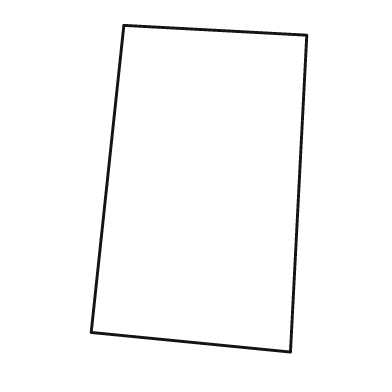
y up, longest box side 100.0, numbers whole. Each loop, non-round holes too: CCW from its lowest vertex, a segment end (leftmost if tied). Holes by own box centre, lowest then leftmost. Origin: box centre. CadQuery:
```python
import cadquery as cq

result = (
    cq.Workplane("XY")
    .moveTo(28.0, -50.0)
    .lineTo(33.0, 47.0)
    .lineTo(-23.0, 50.0)
    .lineTo(-33.0, -44.0)
    .close()
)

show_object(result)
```